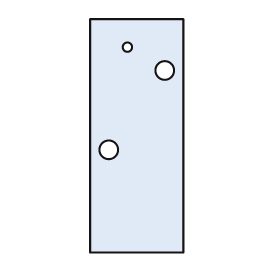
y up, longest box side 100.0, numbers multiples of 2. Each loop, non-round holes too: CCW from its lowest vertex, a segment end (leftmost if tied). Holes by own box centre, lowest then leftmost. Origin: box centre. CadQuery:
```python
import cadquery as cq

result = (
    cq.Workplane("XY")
    .moveTo(-20.0, -50.0)
    .lineTo(20.0, -50.0)
    .lineTo(20.0, 50.0)
    .lineTo(-20.0, 50.0)
    .close()
    .moveTo(-12.0, -6.0)
    .circle(4.0)
    .moveTo(12.0, 28.0)
    .circle(4.0)
    .moveTo(-4.0, 38.0)
    .circle(2.0)
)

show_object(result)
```